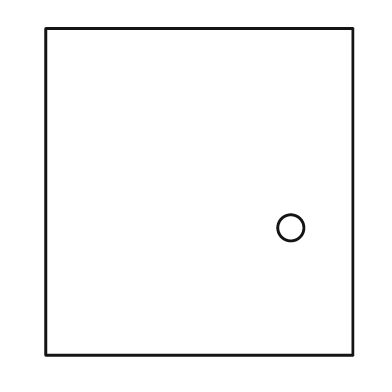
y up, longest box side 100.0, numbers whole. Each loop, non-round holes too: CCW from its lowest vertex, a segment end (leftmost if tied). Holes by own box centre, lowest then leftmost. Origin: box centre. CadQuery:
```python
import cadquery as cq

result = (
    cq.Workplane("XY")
    .moveTo(-47.0, -50.0)
    .lineTo(47.0, -50.0)
    .lineTo(47.0, 50.0)
    .lineTo(-47.0, 50.0)
    .close()
    .moveTo(28.0, -11.0)
    .circle(4.0)
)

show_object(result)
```